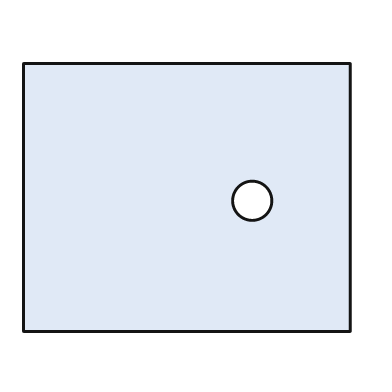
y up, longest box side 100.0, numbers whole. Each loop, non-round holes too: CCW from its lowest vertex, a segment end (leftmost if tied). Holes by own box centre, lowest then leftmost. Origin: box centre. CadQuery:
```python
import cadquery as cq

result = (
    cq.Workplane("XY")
    .moveTo(-50.0, -41.0)
    .lineTo(50.0, -41.0)
    .lineTo(50.0, 41.0)
    .lineTo(-50.0, 41.0)
    .close()
    .moveTo(20.0, -1.0)
    .circle(6.0)
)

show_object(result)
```